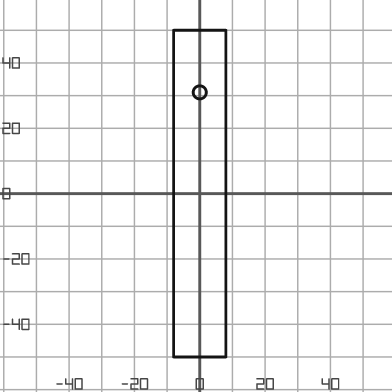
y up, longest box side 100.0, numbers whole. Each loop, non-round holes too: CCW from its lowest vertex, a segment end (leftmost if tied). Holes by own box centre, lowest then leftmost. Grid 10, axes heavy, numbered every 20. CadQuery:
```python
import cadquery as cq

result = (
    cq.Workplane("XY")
    .moveTo(-8.0, -50.0)
    .lineTo(8.0, -50.0)
    .lineTo(8.0, 50.0)
    .lineTo(-8.0, 50.0)
    .close()
    .moveTo(0.0, 31.0)
    .circle(2.0)
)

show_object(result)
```